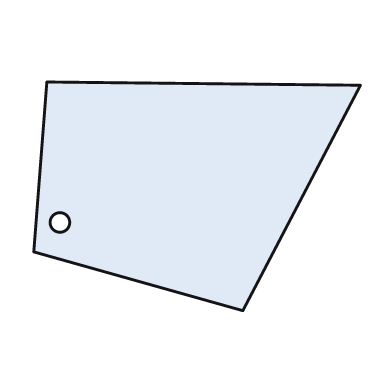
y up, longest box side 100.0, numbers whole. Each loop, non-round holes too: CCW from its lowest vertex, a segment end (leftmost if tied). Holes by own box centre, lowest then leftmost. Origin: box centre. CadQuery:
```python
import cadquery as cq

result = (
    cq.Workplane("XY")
    .moveTo(14.0, -35.0)
    .lineTo(50.0, 34.0)
    .lineTo(-46.0, 35.0)
    .lineTo(-50.0, -17.0)
    .close()
    .moveTo(-42.0, -8.0)
    .circle(3.0)
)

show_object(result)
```